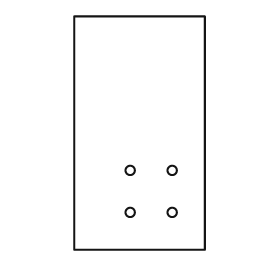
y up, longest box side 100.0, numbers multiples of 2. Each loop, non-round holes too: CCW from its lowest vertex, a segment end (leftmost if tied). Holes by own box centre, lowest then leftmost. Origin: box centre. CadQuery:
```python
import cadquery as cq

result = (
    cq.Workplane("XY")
    .moveTo(-28.0, -50.0)
    .lineTo(28.0, -50.0)
    .lineTo(28.0, 50.0)
    .lineTo(-28.0, 50.0)
    .close()
    .moveTo(-4.0, -34.0)
    .circle(2.0)
    .moveTo(14.0, -34.0)
    .circle(2.0)
    .moveTo(-4.0, -16.0)
    .circle(2.0)
    .moveTo(14.0, -16.0)
    .circle(2.0)
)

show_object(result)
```